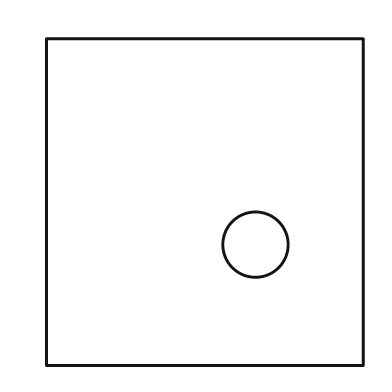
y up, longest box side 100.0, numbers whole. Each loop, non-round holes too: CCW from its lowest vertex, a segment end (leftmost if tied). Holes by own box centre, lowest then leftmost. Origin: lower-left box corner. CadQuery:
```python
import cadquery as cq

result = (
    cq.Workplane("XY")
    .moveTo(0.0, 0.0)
    .lineTo(97.0, 0.0)
    .lineTo(97.0, 100.0)
    .lineTo(0.0, 100.0)
    .close()
    .moveTo(64.0, 37.0)
    .circle(10.0)
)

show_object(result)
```